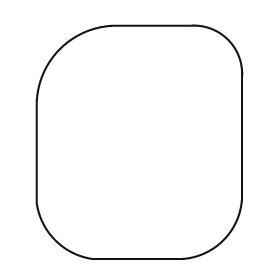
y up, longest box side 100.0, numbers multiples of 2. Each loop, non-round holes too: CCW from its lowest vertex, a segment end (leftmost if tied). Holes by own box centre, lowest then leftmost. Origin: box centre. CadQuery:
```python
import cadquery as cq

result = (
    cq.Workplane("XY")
    .moveTo(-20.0, -50.0)
    .lineTo(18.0, -50.0)
    .threePointArc((36.0, -42.0), (44.0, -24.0))
    .lineTo(44.0, 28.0)
    .threePointArc((38.0, 44.0), (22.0, 50.0))
    .lineTo(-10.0, 50.0)
    .threePointArc((-34.0, 40.0), (-44.0, 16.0))
    .lineTo(-44.0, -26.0)
    .threePointArc((-36.0, -42.0), (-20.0, -50.0))
    .close()
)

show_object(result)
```